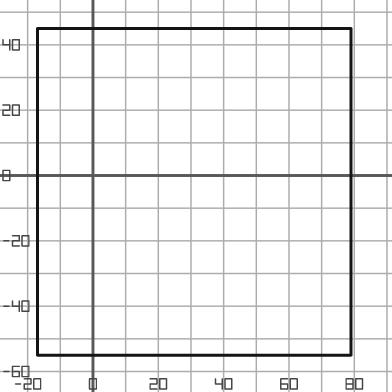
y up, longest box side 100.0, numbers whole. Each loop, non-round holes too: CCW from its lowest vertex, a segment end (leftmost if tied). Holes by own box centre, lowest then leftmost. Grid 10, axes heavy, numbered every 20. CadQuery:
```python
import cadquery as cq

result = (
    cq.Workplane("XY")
    .moveTo(-17.0, -55.0)
    .lineTo(79.0, -55.0)
    .lineTo(79.0, 45.0)
    .lineTo(-17.0, 45.0)
    .close()
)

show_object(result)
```